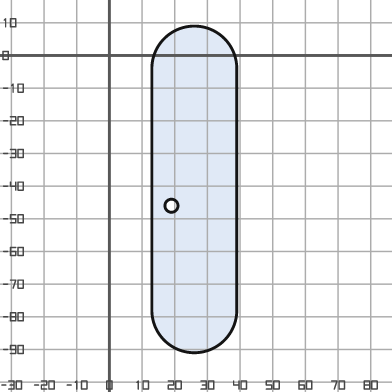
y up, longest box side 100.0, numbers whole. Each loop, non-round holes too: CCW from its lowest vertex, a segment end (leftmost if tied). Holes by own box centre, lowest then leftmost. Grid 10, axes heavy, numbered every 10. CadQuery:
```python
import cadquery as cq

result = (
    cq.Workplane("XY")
    .moveTo(13.0, -78.0)
    .threePointArc((26.0, -91.0), (39.0, -78.0))
    .lineTo(39.0, -4.0)
    .threePointArc((26.0, 9.0), (13.0, -4.0))
    .close()
    .moveTo(19.0, -46.0)
    .circle(2.0)
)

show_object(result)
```